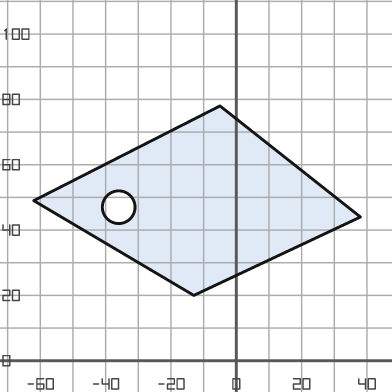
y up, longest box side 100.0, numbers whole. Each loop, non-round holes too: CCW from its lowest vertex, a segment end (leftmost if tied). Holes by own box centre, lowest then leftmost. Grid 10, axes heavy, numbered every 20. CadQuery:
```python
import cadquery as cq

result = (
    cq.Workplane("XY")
    .moveTo(-13.0, 20.0)
    .lineTo(38.0, 44.0)
    .lineTo(-5.0, 78.0)
    .lineTo(-62.0, 49.0)
    .close()
    .moveTo(-36.0, 47.0)
    .circle(5.0)
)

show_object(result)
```